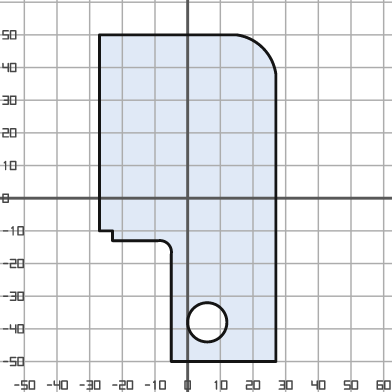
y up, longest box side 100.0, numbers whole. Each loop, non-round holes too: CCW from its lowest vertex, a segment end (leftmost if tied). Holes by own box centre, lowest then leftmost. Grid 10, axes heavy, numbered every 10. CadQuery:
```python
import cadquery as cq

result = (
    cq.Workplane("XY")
    .moveTo(-5.0, -50.0)
    .lineTo(27.0, -50.0)
    .lineTo(27.0, 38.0)
    .threePointArc((23.0, 46.0), (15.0, 50.0))
    .lineTo(-27.0, 50.0)
    .lineTo(-27.0, -10.0)
    .lineTo(-23.0, -10.0)
    .lineTo(-23.0, -13.0)
    .lineTo(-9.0, -13.0)
    .threePointArc((-6.0, -14.0), (-5.0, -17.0))
    .close()
    .moveTo(6.0, -38.0)
    .circle(6.0)
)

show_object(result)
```